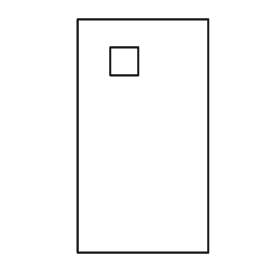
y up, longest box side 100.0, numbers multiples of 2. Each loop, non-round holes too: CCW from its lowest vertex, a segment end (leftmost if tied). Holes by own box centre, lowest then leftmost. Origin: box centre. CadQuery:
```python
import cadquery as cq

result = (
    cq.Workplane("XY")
    .moveTo(-28.0, -50.0)
    .lineTo(28.0, -50.0)
    .lineTo(28.0, 50.0)
    .lineTo(-28.0, 50.0)
    .close()
    .moveTo(-14.0, 26.0)
    .lineTo(-2.0, 26.0)
    .lineTo(-2.0, 38.0)
    .lineTo(-14.0, 38.0)
    .close()
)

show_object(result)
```